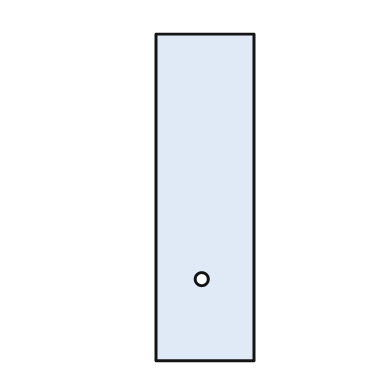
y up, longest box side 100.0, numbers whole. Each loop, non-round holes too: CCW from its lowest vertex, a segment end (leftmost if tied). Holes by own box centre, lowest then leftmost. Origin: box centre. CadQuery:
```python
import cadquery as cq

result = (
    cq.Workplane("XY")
    .moveTo(-15.0, -50.0)
    .lineTo(15.0, -50.0)
    .lineTo(15.0, 50.0)
    .lineTo(-15.0, 50.0)
    .close()
    .moveTo(-1.0, -25.0)
    .circle(2.0)
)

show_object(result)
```